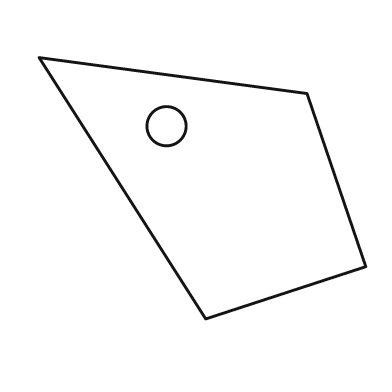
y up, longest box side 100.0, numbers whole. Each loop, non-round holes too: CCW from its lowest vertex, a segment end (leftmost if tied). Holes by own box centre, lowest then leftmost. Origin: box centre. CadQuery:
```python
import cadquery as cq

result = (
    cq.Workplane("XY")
    .moveTo(1.0, -40.0)
    .lineTo(50.0, -24.0)
    .lineTo(32.0, 29.0)
    .lineTo(-50.0, 40.0)
    .close()
    .moveTo(-11.0, 19.0)
    .circle(6.0)
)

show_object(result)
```